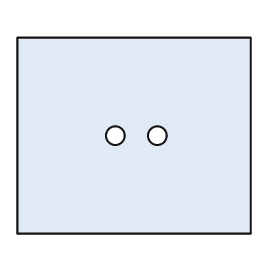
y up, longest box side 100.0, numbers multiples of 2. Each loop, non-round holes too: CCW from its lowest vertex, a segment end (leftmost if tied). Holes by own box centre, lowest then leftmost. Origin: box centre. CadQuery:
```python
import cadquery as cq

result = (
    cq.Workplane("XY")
    .moveTo(-50.0, -42.0)
    .lineTo(50.0, -42.0)
    .lineTo(50.0, 42.0)
    .lineTo(-50.0, 42.0)
    .close()
    .moveTo(-8.0, 0.0)
    .circle(4.0)
    .moveTo(10.0, 0.0)
    .circle(4.0)
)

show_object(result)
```